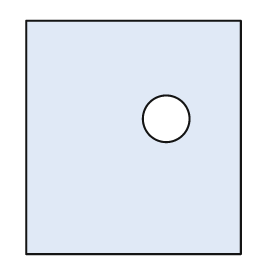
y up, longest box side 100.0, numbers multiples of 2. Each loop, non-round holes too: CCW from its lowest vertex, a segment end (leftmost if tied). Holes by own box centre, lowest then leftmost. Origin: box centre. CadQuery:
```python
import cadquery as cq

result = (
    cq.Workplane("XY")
    .moveTo(-46.0, -50.0)
    .lineTo(46.0, -50.0)
    .lineTo(46.0, 50.0)
    .lineTo(-46.0, 50.0)
    .close()
    .moveTo(14.0, 8.0)
    .circle(10.0)
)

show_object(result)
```